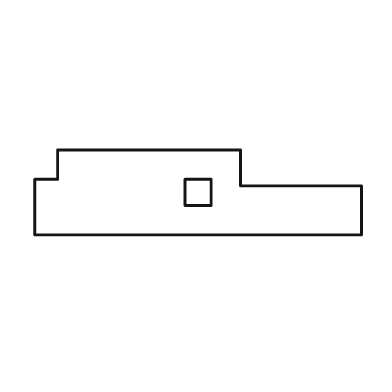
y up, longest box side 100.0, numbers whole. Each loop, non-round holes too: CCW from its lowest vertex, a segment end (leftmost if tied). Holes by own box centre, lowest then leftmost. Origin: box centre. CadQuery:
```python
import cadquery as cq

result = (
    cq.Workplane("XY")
    .moveTo(-50.0, -13.0)
    .lineTo(50.0, -13.0)
    .lineTo(50.0, 2.0)
    .lineTo(13.0, 2.0)
    .lineTo(13.0, 13.0)
    .lineTo(-43.0, 13.0)
    .lineTo(-43.0, 4.0)
    .lineTo(-50.0, 4.0)
    .close()
    .moveTo(-4.0, -4.0)
    .lineTo(4.0, -4.0)
    .lineTo(4.0, 4.0)
    .lineTo(-4.0, 4.0)
    .close()
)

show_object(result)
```